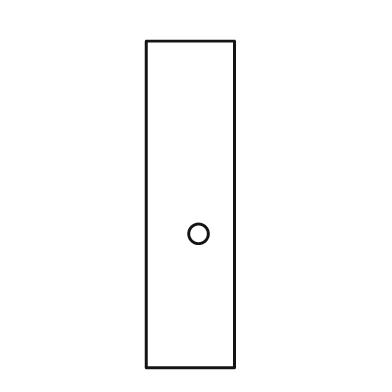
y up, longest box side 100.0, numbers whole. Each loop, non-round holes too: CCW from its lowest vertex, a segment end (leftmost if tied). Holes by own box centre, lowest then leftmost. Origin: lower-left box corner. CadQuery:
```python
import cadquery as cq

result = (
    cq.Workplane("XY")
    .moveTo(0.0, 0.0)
    .lineTo(27.0, 0.0)
    .lineTo(27.0, 100.0)
    .lineTo(0.0, 100.0)
    .close()
    .moveTo(16.0, 41.0)
    .circle(3.0)
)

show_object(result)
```